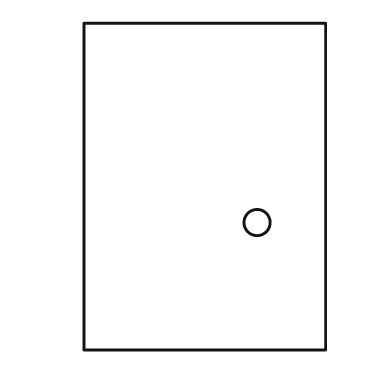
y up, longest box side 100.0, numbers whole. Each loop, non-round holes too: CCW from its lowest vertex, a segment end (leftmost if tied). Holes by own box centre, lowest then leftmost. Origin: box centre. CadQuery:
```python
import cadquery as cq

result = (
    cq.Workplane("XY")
    .moveTo(-37.0, -50.0)
    .lineTo(37.0, -50.0)
    .lineTo(37.0, 50.0)
    .lineTo(-37.0, 50.0)
    .close()
    .moveTo(16.0, -11.0)
    .circle(4.0)
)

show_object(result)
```